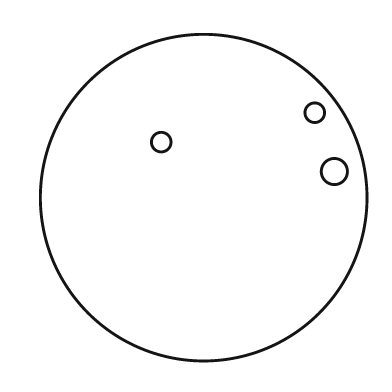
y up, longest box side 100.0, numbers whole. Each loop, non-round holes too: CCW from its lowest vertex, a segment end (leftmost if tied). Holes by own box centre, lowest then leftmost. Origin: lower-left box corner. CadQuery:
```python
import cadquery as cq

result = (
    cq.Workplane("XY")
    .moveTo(50.0, 50.0)
    .circle(50.0)
    .moveTo(90.0, 58.0)
    .circle(4.0)
    .moveTo(37.0, 67.0)
    .circle(3.0)
    .moveTo(84.0, 76.0)
    .circle(3.0)
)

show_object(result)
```